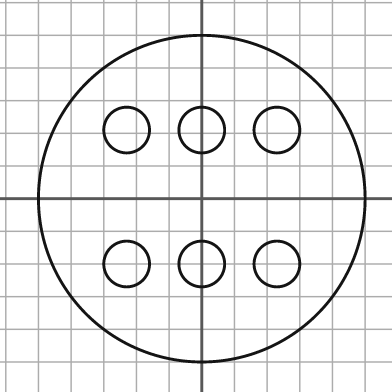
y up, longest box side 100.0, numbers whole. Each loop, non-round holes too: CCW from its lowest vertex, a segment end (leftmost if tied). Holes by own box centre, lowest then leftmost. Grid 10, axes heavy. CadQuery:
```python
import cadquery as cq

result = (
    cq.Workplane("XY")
    .moveTo(0.0, 0.0)
    .circle(50.0)
    .moveTo(-23.0, -20.0)
    .circle(7.0)
    .moveTo(0.0, -20.0)
    .circle(7.0)
    .moveTo(23.0, -20.0)
    .circle(7.0)
    .moveTo(-23.0, 21.0)
    .circle(7.0)
    .moveTo(0.0, 21.0)
    .circle(7.0)
    .moveTo(23.0, 21.0)
    .circle(7.0)
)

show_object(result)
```